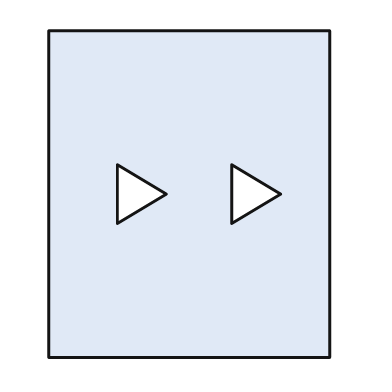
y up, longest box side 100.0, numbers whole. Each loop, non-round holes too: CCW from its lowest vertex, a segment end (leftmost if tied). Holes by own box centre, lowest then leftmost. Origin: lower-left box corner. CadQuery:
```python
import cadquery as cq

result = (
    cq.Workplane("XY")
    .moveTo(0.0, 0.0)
    .lineTo(86.0, 0.0)
    .lineTo(86.0, 100.0)
    .lineTo(0.0, 100.0)
    .close()
    .moveTo(21.0, 41.0)
    .lineTo(36.0, 50.0)
    .lineTo(21.0, 59.0)
    .close()
    .moveTo(56.0, 41.0)
    .lineTo(71.0, 50.0)
    .lineTo(56.0, 59.0)
    .close()
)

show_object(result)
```